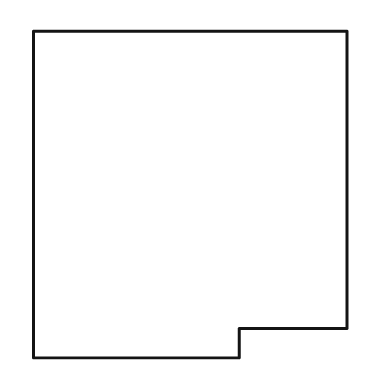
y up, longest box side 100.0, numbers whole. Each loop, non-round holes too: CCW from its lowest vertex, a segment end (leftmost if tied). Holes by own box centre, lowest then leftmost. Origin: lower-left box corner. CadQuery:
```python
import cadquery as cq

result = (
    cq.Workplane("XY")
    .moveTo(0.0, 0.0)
    .lineTo(63.0, 0.0)
    .lineTo(63.0, 9.0)
    .lineTo(96.0, 9.0)
    .lineTo(96.0, 100.0)
    .lineTo(0.0, 100.0)
    .close()
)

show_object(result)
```